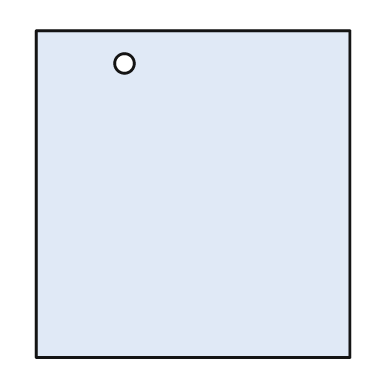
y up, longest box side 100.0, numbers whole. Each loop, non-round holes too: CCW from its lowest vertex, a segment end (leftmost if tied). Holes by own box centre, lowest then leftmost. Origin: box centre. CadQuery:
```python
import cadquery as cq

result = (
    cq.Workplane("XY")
    .moveTo(-48.0, -50.0)
    .lineTo(48.0, -50.0)
    .lineTo(48.0, 50.0)
    .lineTo(-48.0, 50.0)
    .close()
    .moveTo(-21.0, 40.0)
    .circle(3.0)
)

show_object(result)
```